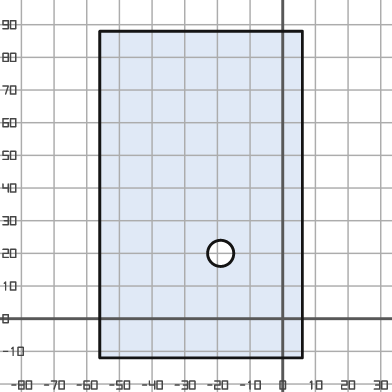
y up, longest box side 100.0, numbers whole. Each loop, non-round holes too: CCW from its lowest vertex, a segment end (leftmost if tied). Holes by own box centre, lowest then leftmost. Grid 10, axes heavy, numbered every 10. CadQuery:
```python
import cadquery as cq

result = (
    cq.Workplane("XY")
    .moveTo(-56.0, -12.0)
    .lineTo(6.0, -12.0)
    .lineTo(6.0, 88.0)
    .lineTo(-56.0, 88.0)
    .close()
    .moveTo(-19.0, 20.0)
    .circle(4.0)
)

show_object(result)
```